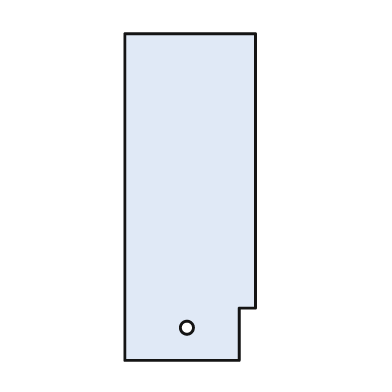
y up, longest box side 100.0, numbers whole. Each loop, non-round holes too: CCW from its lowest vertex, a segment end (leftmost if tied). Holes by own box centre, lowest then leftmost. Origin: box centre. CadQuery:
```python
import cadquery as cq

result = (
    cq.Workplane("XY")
    .moveTo(-20.0, -50.0)
    .lineTo(15.0, -50.0)
    .lineTo(15.0, -34.0)
    .lineTo(20.0, -34.0)
    .lineTo(20.0, 50.0)
    .lineTo(-20.0, 50.0)
    .close()
    .moveTo(-1.0, -40.0)
    .circle(2.0)
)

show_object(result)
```